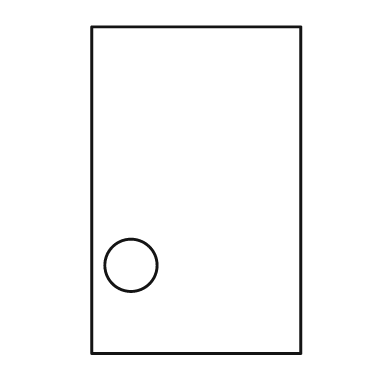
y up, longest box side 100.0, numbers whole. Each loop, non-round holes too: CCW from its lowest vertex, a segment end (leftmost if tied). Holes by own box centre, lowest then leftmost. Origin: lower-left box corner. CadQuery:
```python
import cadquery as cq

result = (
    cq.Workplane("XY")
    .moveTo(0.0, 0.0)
    .lineTo(64.0, 0.0)
    .lineTo(64.0, 100.0)
    .lineTo(0.0, 100.0)
    .close()
    .moveTo(12.0, 27.0)
    .circle(8.0)
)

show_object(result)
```